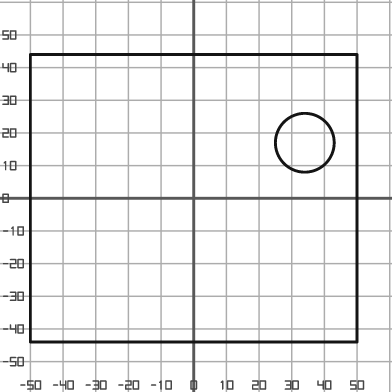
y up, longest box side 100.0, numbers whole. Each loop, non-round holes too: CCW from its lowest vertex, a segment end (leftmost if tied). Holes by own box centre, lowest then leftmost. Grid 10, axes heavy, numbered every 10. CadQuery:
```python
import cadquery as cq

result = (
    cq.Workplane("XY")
    .moveTo(-50.0, -44.0)
    .lineTo(50.0, -44.0)
    .lineTo(50.0, 44.0)
    .lineTo(-50.0, 44.0)
    .close()
    .moveTo(34.0, 17.0)
    .circle(9.0)
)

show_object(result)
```